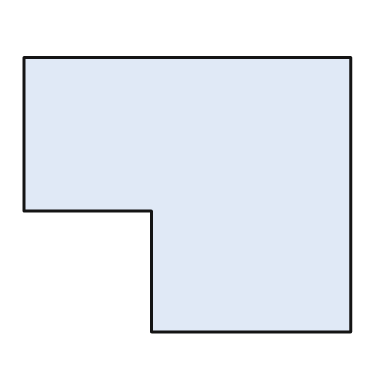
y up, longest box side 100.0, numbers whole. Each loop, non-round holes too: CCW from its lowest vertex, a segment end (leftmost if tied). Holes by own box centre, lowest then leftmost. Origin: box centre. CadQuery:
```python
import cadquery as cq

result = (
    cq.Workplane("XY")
    .moveTo(-11.0, -42.0)
    .lineTo(50.0, -42.0)
    .lineTo(50.0, 42.0)
    .lineTo(-50.0, 42.0)
    .lineTo(-50.0, -5.0)
    .lineTo(-11.0, -5.0)
    .close()
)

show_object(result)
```